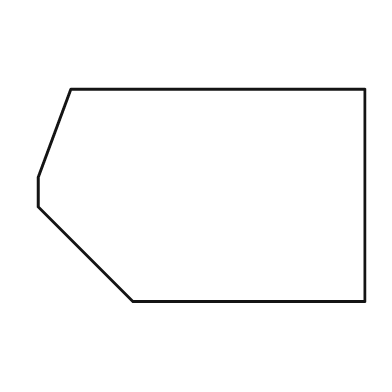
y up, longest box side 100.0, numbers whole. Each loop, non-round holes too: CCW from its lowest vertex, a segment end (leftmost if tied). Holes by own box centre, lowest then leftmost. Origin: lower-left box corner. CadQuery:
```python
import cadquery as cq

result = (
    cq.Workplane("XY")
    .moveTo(29.0, 0.0)
    .lineTo(100.0, 0.0)
    .lineTo(100.0, 65.0)
    .lineTo(10.0, 65.0)
    .lineTo(0.0, 38.0)
    .lineTo(0.0, 29.0)
    .close()
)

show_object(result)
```